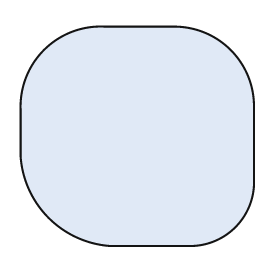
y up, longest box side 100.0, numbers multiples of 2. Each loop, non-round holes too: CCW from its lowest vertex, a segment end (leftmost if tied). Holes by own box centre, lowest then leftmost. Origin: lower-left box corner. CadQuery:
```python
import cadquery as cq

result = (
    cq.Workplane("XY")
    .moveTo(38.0, 0.0)
    .lineTo(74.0, 0.0)
    .threePointArc((92.0, 8.0), (100.0, 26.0))
    .lineTo(100.0, 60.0)
    .threePointArc((90.0, 84.0), (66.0, 94.0))
    .lineTo(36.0, 94.0)
    .threePointArc((10.0, 84.0), (0.0, 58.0))
    .lineTo(0.0, 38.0)
    .threePointArc((12.0, 12.0), (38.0, 0.0))
    .close()
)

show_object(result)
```